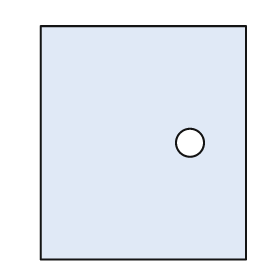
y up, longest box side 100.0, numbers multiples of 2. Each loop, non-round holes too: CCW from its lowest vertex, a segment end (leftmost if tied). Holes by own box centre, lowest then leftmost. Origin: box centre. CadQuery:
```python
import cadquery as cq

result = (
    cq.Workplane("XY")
    .moveTo(-44.0, -50.0)
    .lineTo(44.0, -50.0)
    .lineTo(44.0, 50.0)
    .lineTo(-44.0, 50.0)
    .close()
    .moveTo(20.0, 0.0)
    .circle(6.0)
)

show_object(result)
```